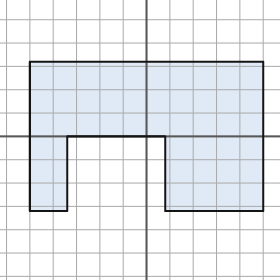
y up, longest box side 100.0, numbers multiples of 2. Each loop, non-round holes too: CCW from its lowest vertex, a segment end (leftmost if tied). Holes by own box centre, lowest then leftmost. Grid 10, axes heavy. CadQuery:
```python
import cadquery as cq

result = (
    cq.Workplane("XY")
    .moveTo(-50.0, -32.0)
    .lineTo(-34.0, -32.0)
    .lineTo(-34.0, 0.0)
    .lineTo(8.0, 0.0)
    .lineTo(8.0, -32.0)
    .lineTo(50.0, -32.0)
    .lineTo(50.0, 32.0)
    .lineTo(-50.0, 32.0)
    .close()
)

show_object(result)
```